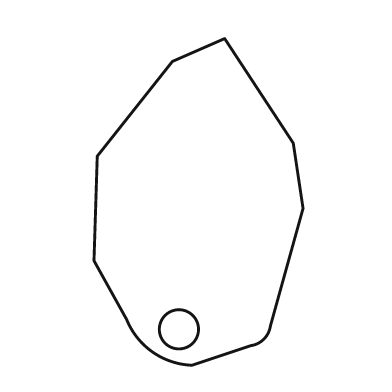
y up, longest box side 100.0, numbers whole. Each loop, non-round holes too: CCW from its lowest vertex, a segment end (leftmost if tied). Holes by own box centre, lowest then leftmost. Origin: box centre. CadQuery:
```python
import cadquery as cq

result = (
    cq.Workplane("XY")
    .moveTo(-2.0, -50.0)
    .lineTo(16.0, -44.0)
    .threePointArc((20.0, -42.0), (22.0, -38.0))
    .lineTo(32.0, -2.0)
    .lineTo(29.0, 18.0)
    .lineTo(8.0, 50.0)
    .lineTo(-8.0, 43.0)
    .lineTo(-31.0, 14.0)
    .lineTo(-32.0, -18.0)
    .lineTo(-22.0, -36.0)
    .threePointArc((-14.0, -46.0), (-2.0, -50.0))
    .close()
    .moveTo(-6.0, -39.0)
    .circle(6.0)
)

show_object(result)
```